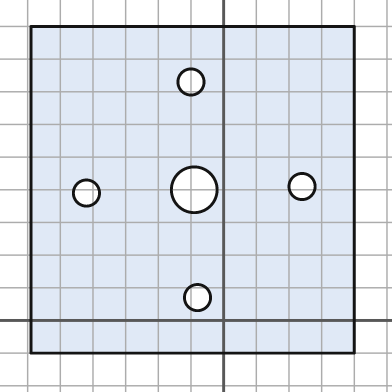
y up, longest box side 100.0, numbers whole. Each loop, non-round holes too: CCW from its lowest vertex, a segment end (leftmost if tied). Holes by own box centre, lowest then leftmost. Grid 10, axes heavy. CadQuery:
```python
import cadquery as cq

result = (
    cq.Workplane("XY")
    .moveTo(-59.0, -10.0)
    .lineTo(40.0, -10.0)
    .lineTo(40.0, 90.0)
    .lineTo(-59.0, 90.0)
    .close()
    .moveTo(-8.0, 7.0)
    .circle(4.0)
    .moveTo(-42.0, 39.0)
    .circle(4.0)
    .moveTo(-9.0, 40.0)
    .circle(7.0)
    .moveTo(24.0, 41.0)
    .circle(4.0)
    .moveTo(-10.0, 73.0)
    .circle(4.0)
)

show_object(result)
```